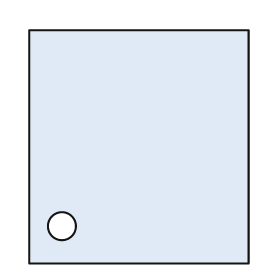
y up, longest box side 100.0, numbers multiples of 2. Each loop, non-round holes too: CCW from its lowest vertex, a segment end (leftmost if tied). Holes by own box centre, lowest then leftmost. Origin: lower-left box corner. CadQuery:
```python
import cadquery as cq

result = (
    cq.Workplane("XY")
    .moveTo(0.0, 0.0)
    .lineTo(94.0, 0.0)
    .lineTo(94.0, 100.0)
    .lineTo(0.0, 100.0)
    .close()
    .moveTo(14.0, 16.0)
    .circle(6.0)
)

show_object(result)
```